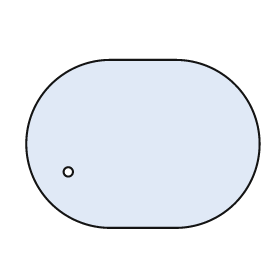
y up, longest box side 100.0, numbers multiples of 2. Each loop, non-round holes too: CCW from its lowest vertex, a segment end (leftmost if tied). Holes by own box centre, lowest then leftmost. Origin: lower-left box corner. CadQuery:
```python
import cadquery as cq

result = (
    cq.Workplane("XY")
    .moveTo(36.0, 0.0)
    .lineTo(64.0, 0.0)
    .threePointArc((100.0, 36.0), (64.0, 72.0))
    .lineTo(36.0, 72.0)
    .threePointArc((0.0, 36.0), (36.0, 0.0))
    .close()
    .moveTo(18.0, 24.0)
    .circle(2.0)
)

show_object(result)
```